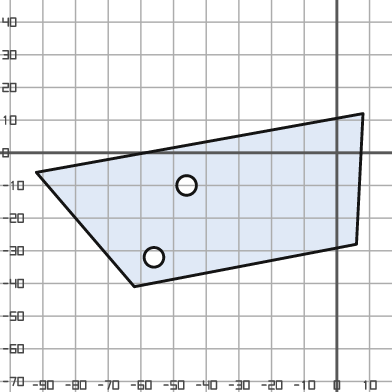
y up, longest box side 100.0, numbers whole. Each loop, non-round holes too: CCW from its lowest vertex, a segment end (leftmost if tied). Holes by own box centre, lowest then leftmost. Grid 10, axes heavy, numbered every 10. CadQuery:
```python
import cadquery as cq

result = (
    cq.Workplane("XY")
    .moveTo(-62.0, -41.0)
    .lineTo(6.0, -28.0)
    .lineTo(8.0, 12.0)
    .lineTo(-92.0, -6.0)
    .close()
    .moveTo(-56.0, -32.0)
    .circle(3.0)
    .moveTo(-46.0, -10.0)
    .circle(3.0)
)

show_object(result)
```